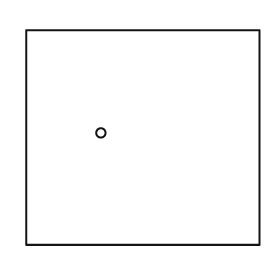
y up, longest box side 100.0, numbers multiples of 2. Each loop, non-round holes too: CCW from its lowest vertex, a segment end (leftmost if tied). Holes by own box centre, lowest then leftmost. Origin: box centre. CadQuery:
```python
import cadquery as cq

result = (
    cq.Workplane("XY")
    .moveTo(-50.0, -46.0)
    .lineTo(50.0, -46.0)
    .lineTo(50.0, 46.0)
    .lineTo(-50.0, 46.0)
    .close()
    .moveTo(-18.0, 2.0)
    .circle(2.0)
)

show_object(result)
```